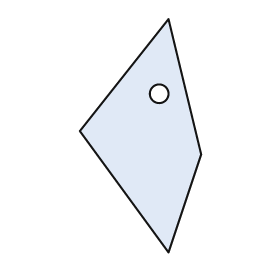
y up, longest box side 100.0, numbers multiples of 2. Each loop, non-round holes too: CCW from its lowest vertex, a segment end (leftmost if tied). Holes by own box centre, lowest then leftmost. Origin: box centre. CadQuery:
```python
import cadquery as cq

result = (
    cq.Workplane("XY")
    .moveTo(12.0, -50.0)
    .lineTo(26.0, -8.0)
    .lineTo(12.0, 50.0)
    .lineTo(-26.0, 2.0)
    .close()
    .moveTo(8.0, 18.0)
    .circle(4.0)
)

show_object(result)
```